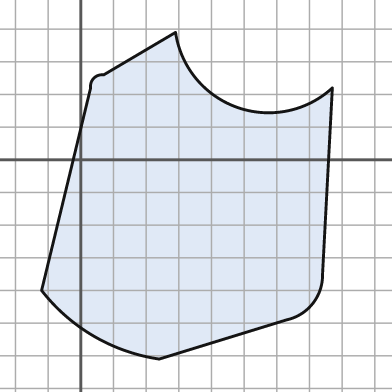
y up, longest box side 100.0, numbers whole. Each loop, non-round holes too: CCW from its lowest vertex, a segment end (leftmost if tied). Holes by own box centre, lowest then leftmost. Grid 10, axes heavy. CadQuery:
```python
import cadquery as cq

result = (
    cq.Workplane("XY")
    .moveTo(24.0, -61.0)
    .lineTo(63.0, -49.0)
    .threePointArc((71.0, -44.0), (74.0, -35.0))
    .lineTo(77.0, 22.0)
    .threePointArc((48.0, 16.0), (29.0, 39.0))
    .lineTo(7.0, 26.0)
    .threePointArc((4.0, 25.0), (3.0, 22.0))
    .lineTo(-12.0, -40.0)
    .threePointArc((4.0, -54.0), (24.0, -61.0))
    .close()
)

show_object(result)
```